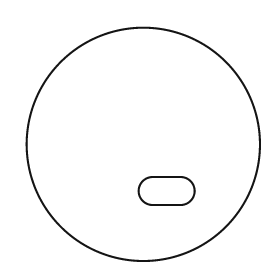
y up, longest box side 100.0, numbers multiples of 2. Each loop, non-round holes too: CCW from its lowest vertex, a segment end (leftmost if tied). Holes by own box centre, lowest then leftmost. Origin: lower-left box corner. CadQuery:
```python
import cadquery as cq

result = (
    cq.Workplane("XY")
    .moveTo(50.0, 50.0)
    .circle(50.0)
    .moveTo(54.0, 24.0)
    .lineTo(66.0, 24.0)
    .threePointArc((72.0, 30.0), (66.0, 36.0))
    .lineTo(54.0, 36.0)
    .threePointArc((48.0, 30.0), (54.0, 24.0))
    .close()
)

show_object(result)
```